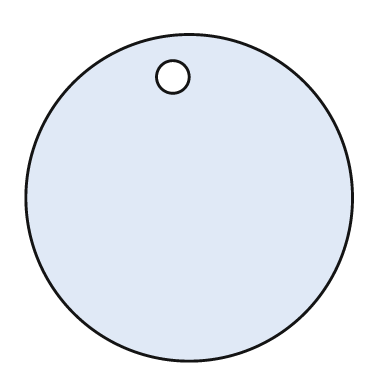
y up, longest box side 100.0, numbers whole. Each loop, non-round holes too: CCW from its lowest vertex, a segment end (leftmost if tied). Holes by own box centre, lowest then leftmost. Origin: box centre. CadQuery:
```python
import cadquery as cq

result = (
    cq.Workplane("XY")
    .moveTo(0.0, 0.0)
    .circle(50.0)
    .moveTo(-5.0, 37.0)
    .circle(5.0)
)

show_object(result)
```